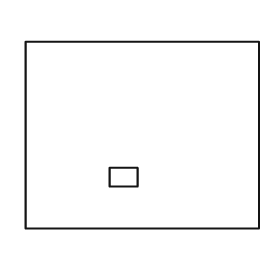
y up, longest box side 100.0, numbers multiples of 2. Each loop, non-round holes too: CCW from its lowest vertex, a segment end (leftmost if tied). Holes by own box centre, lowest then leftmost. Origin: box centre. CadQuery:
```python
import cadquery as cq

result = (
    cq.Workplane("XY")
    .moveTo(-50.0, -40.0)
    .lineTo(50.0, -40.0)
    .lineTo(50.0, 40.0)
    .lineTo(-50.0, 40.0)
    .close()
    .moveTo(-14.0, -22.0)
    .lineTo(-2.0, -22.0)
    .lineTo(-2.0, -14.0)
    .lineTo(-14.0, -14.0)
    .close()
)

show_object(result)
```